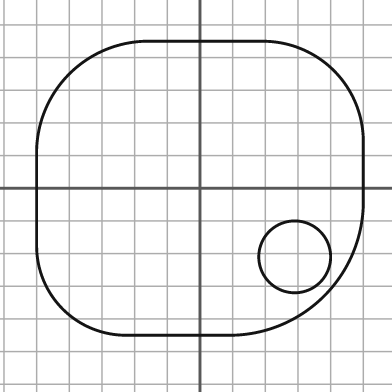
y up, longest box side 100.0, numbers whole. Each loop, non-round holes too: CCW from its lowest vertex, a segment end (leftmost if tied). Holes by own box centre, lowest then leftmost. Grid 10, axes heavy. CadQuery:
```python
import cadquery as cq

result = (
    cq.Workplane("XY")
    .moveTo(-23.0, -45.0)
    .lineTo(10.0, -45.0)
    .threePointArc((38.0, -33.0), (50.0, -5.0))
    .lineTo(50.0, 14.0)
    .threePointArc((41.0, 36.0), (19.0, 45.0))
    .lineTo(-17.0, 45.0)
    .threePointArc((-40.0, 35.0), (-50.0, 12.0))
    .lineTo(-50.0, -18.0)
    .threePointArc((-42.0, -37.0), (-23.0, -45.0))
    .close()
    .moveTo(29.0, -21.0)
    .circle(11.0)
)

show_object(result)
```